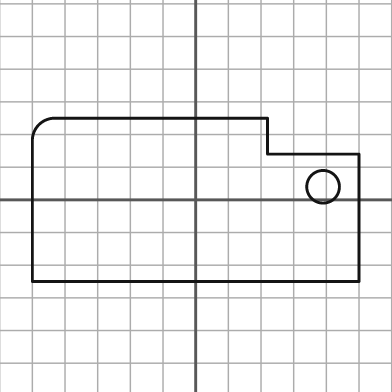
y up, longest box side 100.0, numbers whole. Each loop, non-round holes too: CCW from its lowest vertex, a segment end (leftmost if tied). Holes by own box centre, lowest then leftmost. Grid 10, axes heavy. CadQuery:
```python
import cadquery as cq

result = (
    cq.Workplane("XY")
    .moveTo(-50.0, -25.0)
    .lineTo(50.0, -25.0)
    .lineTo(50.0, 14.0)
    .lineTo(22.0, 14.0)
    .lineTo(22.0, 25.0)
    .lineTo(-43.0, 25.0)
    .threePointArc((-48.0, 23.0), (-50.0, 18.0))
    .close()
    .moveTo(39.0, 4.0)
    .circle(5.0)
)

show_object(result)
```